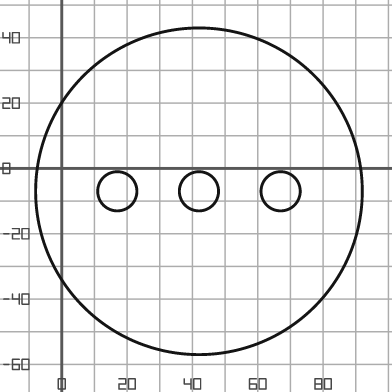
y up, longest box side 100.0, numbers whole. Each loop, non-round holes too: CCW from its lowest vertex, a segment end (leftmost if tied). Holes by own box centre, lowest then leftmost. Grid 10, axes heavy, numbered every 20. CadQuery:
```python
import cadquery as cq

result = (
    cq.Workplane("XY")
    .moveTo(42.0, -7.0)
    .circle(50.0)
    .moveTo(17.0, -7.0)
    .circle(6.0)
    .moveTo(42.0, -7.0)
    .circle(6.0)
    .moveTo(67.0, -7.0)
    .circle(6.0)
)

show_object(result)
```